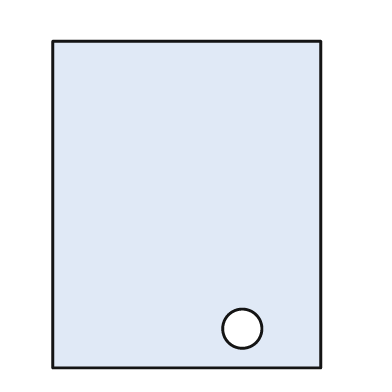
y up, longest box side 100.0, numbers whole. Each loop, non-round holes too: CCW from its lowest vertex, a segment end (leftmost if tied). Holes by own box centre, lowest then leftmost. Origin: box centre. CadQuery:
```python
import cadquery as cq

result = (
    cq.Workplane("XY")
    .moveTo(-41.0, -50.0)
    .lineTo(41.0, -50.0)
    .lineTo(41.0, 50.0)
    .lineTo(-41.0, 50.0)
    .close()
    .moveTo(17.0, -38.0)
    .circle(6.0)
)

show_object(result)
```